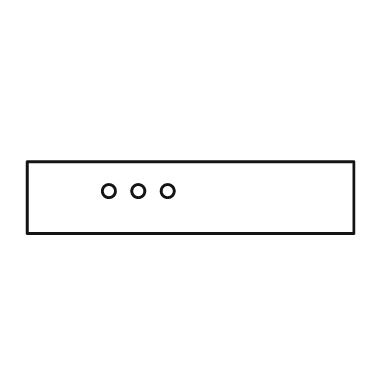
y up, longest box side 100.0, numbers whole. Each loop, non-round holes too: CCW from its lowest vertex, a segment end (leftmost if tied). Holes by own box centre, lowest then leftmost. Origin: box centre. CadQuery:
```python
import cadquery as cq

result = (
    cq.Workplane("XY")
    .moveTo(-50.0, -11.0)
    .lineTo(50.0, -11.0)
    .lineTo(50.0, 11.0)
    .lineTo(-50.0, 11.0)
    .close()
    .moveTo(-25.0, 2.0)
    .circle(2.0)
    .moveTo(-16.0, 2.0)
    .circle(2.0)
    .moveTo(-7.0, 2.0)
    .circle(2.0)
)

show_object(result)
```